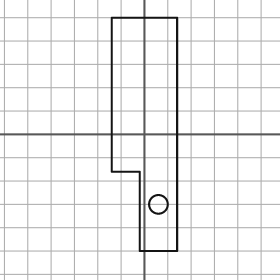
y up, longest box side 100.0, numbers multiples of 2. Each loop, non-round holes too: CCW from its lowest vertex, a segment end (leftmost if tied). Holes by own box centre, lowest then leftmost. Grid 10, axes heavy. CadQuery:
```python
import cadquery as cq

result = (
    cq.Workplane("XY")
    .moveTo(-2.0, -50.0)
    .lineTo(14.0, -50.0)
    .lineTo(14.0, 50.0)
    .lineTo(-14.0, 50.0)
    .lineTo(-14.0, -16.0)
    .lineTo(-2.0, -16.0)
    .close()
    .moveTo(6.0, -30.0)
    .circle(4.0)
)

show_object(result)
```